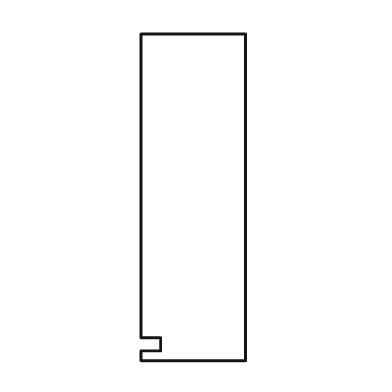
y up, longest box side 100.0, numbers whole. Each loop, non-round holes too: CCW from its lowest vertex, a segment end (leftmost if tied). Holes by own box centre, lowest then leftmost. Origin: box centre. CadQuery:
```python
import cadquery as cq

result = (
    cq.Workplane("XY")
    .moveTo(-16.0, -50.0)
    .lineTo(16.0, -50.0)
    .lineTo(16.0, 50.0)
    .lineTo(-16.0, 50.0)
    .lineTo(-16.0, -43.0)
    .lineTo(-10.0, -43.0)
    .lineTo(-10.0, -47.0)
    .lineTo(-16.0, -47.0)
    .close()
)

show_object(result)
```